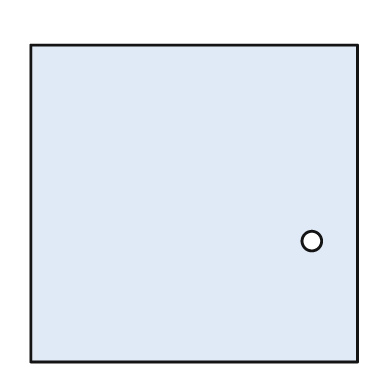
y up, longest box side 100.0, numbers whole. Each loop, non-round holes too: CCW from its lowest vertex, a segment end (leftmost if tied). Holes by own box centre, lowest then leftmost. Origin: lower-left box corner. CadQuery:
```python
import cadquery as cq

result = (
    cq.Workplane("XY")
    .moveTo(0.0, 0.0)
    .lineTo(100.0, 0.0)
    .lineTo(100.0, 97.0)
    .lineTo(0.0, 97.0)
    .close()
    .moveTo(86.0, 37.0)
    .circle(3.0)
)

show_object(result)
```